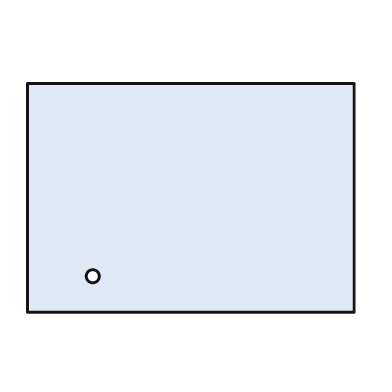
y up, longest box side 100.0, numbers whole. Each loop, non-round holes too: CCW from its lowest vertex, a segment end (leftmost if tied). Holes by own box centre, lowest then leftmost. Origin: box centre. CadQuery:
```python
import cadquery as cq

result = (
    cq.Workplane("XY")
    .moveTo(-50.0, -35.0)
    .lineTo(50.0, -35.0)
    .lineTo(50.0, 35.0)
    .lineTo(-50.0, 35.0)
    .close()
    .moveTo(-30.0, -24.0)
    .circle(2.0)
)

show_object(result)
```